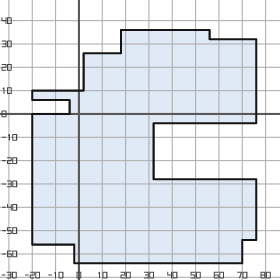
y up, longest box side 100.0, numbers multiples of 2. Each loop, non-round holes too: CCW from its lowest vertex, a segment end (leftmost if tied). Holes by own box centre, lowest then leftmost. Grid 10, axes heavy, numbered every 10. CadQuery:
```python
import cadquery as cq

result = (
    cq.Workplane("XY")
    .moveTo(-2.0, -64.0)
    .lineTo(70.0, -64.0)
    .lineTo(70.0, -54.0)
    .lineTo(76.0, -54.0)
    .lineTo(76.0, -28.0)
    .lineTo(32.0, -28.0)
    .lineTo(32.0, -4.0)
    .lineTo(76.0, -4.0)
    .lineTo(76.0, 32.0)
    .lineTo(56.0, 32.0)
    .lineTo(56.0, 36.0)
    .lineTo(18.0, 36.0)
    .lineTo(18.0, 26.0)
    .lineTo(2.0, 26.0)
    .lineTo(2.0, 10.0)
    .lineTo(-20.0, 10.0)
    .lineTo(-20.0, 6.0)
    .lineTo(-4.0, 6.0)
    .lineTo(-4.0, 0.0)
    .lineTo(-20.0, 0.0)
    .lineTo(-20.0, -56.0)
    .lineTo(-2.0, -56.0)
    .close()
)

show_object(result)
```